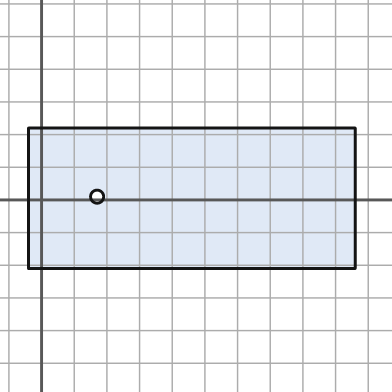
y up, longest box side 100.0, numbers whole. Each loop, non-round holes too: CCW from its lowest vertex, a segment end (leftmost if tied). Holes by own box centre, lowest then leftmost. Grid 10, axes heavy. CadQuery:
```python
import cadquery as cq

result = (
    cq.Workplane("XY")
    .moveTo(-4.0, -21.0)
    .lineTo(96.0, -21.0)
    .lineTo(96.0, 22.0)
    .lineTo(-4.0, 22.0)
    .close()
    .moveTo(17.0, 1.0)
    .circle(2.0)
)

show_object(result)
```